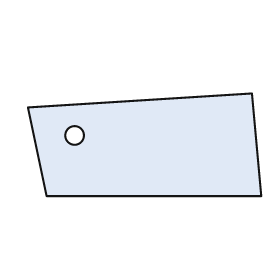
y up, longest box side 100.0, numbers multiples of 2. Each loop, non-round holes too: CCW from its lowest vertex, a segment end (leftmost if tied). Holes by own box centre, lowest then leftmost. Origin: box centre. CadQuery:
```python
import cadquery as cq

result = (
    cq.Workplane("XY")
    .moveTo(-42.0, -22.0)
    .lineTo(50.0, -22.0)
    .lineTo(46.0, 22.0)
    .lineTo(-50.0, 16.0)
    .close()
    .moveTo(-30.0, 4.0)
    .circle(4.0)
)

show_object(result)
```